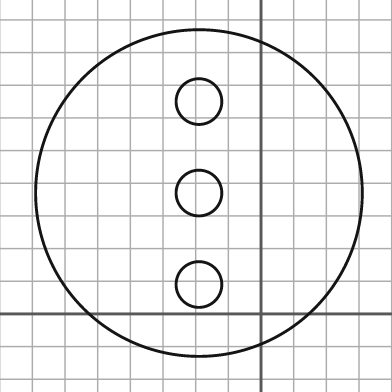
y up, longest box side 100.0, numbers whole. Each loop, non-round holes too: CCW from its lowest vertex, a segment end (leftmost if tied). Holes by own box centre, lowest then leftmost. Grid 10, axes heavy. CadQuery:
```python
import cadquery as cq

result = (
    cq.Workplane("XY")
    .moveTo(-19.0, 37.0)
    .circle(50.0)
    .moveTo(-19.0, 9.0)
    .circle(7.0)
    .moveTo(-19.0, 37.0)
    .circle(7.0)
    .moveTo(-19.0, 65.0)
    .circle(7.0)
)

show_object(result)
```